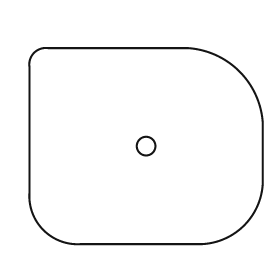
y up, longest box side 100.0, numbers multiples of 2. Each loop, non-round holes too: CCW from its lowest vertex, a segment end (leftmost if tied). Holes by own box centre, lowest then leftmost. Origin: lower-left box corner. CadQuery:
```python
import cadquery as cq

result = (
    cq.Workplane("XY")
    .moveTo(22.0, 0.0)
    .lineTo(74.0, 0.0)
    .threePointArc((92.0, 8.0), (100.0, 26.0))
    .lineTo(100.0, 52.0)
    .threePointArc((90.0, 74.0), (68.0, 84.0))
    .lineTo(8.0, 84.0)
    .threePointArc((2.0, 82.0), (0.0, 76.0))
    .lineTo(0.0, 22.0)
    .threePointArc((6.0, 6.0), (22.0, 0.0))
    .close()
    .moveTo(50.0, 42.0)
    .circle(4.0)
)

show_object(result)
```